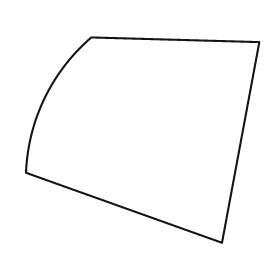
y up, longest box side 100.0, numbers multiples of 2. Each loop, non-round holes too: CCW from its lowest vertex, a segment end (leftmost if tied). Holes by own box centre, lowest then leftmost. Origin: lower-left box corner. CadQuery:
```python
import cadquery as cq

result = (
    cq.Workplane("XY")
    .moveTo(84.0, 0.0)
    .lineTo(100.0, 86.0)
    .lineTo(28.0, 88.0)
    .threePointArc((8.0, 62.0), (0.0, 30.0))
    .close()
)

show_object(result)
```